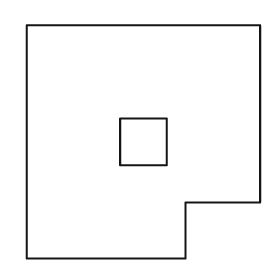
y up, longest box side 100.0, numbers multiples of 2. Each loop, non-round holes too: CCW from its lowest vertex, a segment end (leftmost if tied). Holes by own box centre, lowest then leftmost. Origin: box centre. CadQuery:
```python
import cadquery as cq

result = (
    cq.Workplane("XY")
    .moveTo(-50.0, -50.0)
    .lineTo(18.0, -50.0)
    .lineTo(18.0, -26.0)
    .lineTo(50.0, -26.0)
    .lineTo(50.0, 50.0)
    .lineTo(-50.0, 50.0)
    .close()
    .moveTo(-10.0, -10.0)
    .lineTo(10.0, -10.0)
    .lineTo(10.0, 10.0)
    .lineTo(-10.0, 10.0)
    .close()
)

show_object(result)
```